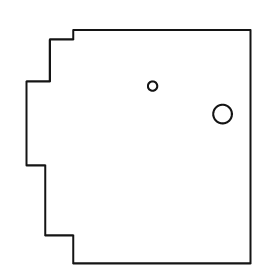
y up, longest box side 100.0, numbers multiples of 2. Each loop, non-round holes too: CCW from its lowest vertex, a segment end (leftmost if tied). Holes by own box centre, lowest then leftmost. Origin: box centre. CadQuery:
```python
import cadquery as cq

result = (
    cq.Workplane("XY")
    .moveTo(-28.0, -50.0)
    .lineTo(48.0, -50.0)
    .lineTo(48.0, 50.0)
    .lineTo(-28.0, 50.0)
    .lineTo(-28.0, 46.0)
    .lineTo(-38.0, 46.0)
    .lineTo(-38.0, 28.0)
    .lineTo(-48.0, 28.0)
    .lineTo(-48.0, -8.0)
    .lineTo(-40.0, -8.0)
    .lineTo(-40.0, -38.0)
    .lineTo(-28.0, -38.0)
    .close()
    .moveTo(36.0, 14.0)
    .circle(4.0)
    .moveTo(6.0, 26.0)
    .circle(2.0)
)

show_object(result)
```